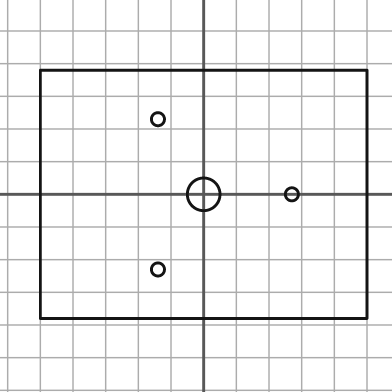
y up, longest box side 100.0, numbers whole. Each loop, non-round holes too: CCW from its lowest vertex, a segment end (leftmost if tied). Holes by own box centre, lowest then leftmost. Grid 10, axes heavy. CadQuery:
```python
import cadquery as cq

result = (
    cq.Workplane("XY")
    .moveTo(-50.0, -38.0)
    .lineTo(50.0, -38.0)
    .lineTo(50.0, 38.0)
    .lineTo(-50.0, 38.0)
    .close()
    .moveTo(-14.0, -23.0)
    .circle(2.0)
    .moveTo(0.0, 0.0)
    .circle(5.0)
    .moveTo(27.0, 0.0)
    .circle(2.0)
    .moveTo(-14.0, 23.0)
    .circle(2.0)
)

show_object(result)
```